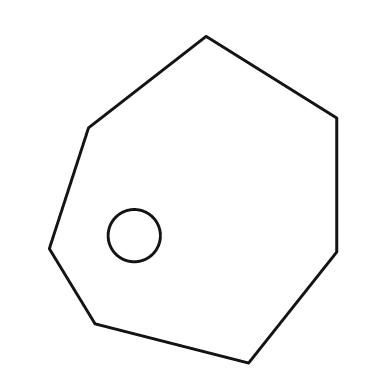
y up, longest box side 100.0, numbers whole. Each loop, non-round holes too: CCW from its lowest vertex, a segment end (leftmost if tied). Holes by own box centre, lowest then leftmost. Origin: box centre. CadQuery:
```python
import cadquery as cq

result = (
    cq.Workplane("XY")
    .moveTo(17.0, -50.0)
    .lineTo(44.0, -16.0)
    .lineTo(44.0, 25.0)
    .lineTo(4.0, 50.0)
    .lineTo(-32.0, 22.0)
    .lineTo(-44.0, -15.0)
    .lineTo(-30.0, -38.0)
    .close()
    .moveTo(-18.0, -11.0)
    .circle(8.0)
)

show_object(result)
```